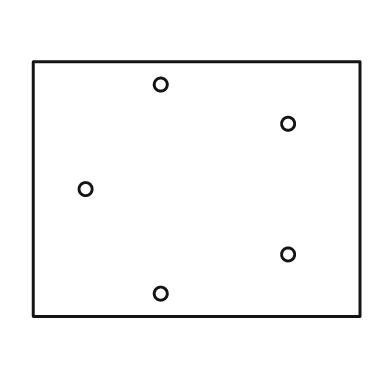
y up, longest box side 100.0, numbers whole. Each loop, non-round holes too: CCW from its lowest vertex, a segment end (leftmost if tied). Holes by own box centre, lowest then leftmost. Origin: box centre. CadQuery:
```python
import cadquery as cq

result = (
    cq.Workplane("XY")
    .moveTo(-50.0, -39.0)
    .lineTo(50.0, -39.0)
    .lineTo(50.0, 39.0)
    .lineTo(-50.0, 39.0)
    .close()
    .moveTo(-11.0, -32.0)
    .circle(2.0)
    .moveTo(28.0, -20.0)
    .circle(2.0)
    .moveTo(-34.0, 0.0)
    .circle(2.0)
    .moveTo(28.0, 20.0)
    .circle(2.0)
    .moveTo(-11.0, 32.0)
    .circle(2.0)
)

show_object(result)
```